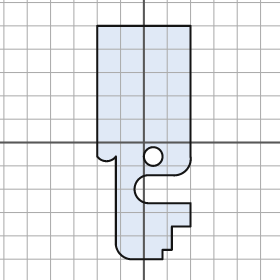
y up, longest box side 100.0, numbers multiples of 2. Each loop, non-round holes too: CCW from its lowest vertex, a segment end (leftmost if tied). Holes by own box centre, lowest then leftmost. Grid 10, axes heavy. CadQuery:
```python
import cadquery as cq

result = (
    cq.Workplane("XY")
    .moveTo(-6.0, -50.0)
    .lineTo(8.0, -50.0)
    .lineTo(8.0, -46.0)
    .lineTo(12.0, -46.0)
    .lineTo(12.0, -36.0)
    .lineTo(20.0, -36.0)
    .lineTo(20.0, -26.0)
    .lineTo(2.0, -26.0)
    .threePointArc((-4.0, -20.0), (2.0, -14.0))
    .lineTo(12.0, -14.0)
    .threePointArc((18.0, -12.0), (20.0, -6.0))
    .lineTo(20.0, 50.0)
    .lineTo(-20.0, 50.0)
    .lineTo(-20.0, -6.0)
    .threePointArc((-16.0, -8.0), (-12.0, -6.0))
    .lineTo(-12.0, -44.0)
    .threePointArc((-10.0, -48.0), (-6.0, -50.0))
    .close()
    .moveTo(4.0, -6.0)
    .circle(4.0)
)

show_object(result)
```